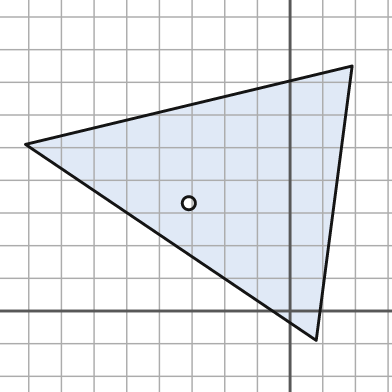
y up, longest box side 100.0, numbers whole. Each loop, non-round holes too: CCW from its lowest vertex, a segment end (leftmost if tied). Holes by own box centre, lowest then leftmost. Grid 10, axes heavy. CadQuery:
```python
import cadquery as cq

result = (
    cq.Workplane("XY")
    .moveTo(8.0, -9.0)
    .lineTo(19.0, 75.0)
    .lineTo(-81.0, 51.0)
    .close()
    .moveTo(-31.0, 33.0)
    .circle(2.0)
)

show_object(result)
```